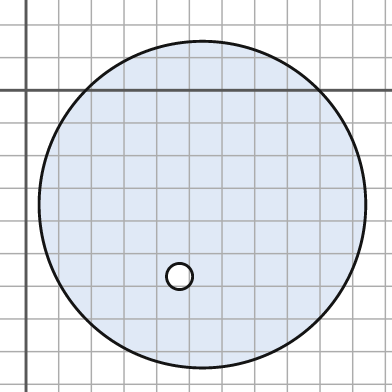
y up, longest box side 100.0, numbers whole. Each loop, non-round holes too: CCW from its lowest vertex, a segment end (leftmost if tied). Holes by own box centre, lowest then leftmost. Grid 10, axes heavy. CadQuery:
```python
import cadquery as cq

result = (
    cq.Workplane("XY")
    .moveTo(54.0, -35.0)
    .circle(50.0)
    .moveTo(47.0, -57.0)
    .circle(4.0)
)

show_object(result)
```